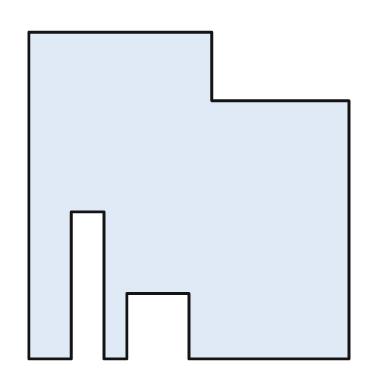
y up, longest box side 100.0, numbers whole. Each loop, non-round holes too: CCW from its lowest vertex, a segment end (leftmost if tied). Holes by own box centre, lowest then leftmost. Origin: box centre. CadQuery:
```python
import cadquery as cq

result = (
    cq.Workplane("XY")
    .moveTo(-49.0, -50.0)
    .lineTo(-36.0, -50.0)
    .lineTo(-36.0, -5.0)
    .lineTo(-26.0, -5.0)
    .lineTo(-26.0, -50.0)
    .lineTo(-19.0, -50.0)
    .lineTo(-19.0, -30.0)
    .lineTo(0.0, -30.0)
    .lineTo(0.0, -50.0)
    .lineTo(49.0, -50.0)
    .lineTo(49.0, 29.0)
    .lineTo(7.0, 29.0)
    .lineTo(7.0, 50.0)
    .lineTo(-49.0, 50.0)
    .close()
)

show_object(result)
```